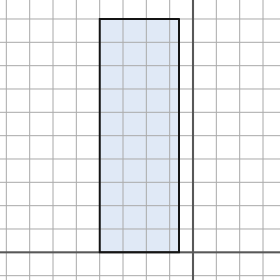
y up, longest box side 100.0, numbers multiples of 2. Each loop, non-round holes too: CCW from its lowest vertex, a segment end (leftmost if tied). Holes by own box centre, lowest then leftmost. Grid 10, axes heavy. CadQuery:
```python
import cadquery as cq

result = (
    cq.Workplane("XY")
    .moveTo(-40.0, 0.0)
    .lineTo(-6.0, 0.0)
    .lineTo(-6.0, 100.0)
    .lineTo(-40.0, 100.0)
    .close()
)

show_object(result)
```